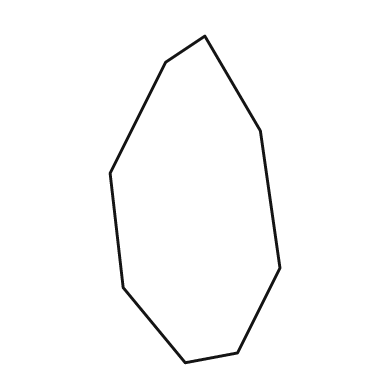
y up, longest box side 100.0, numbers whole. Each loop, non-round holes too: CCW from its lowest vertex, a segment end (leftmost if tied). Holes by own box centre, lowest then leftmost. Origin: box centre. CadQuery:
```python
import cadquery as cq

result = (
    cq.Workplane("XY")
    .moveTo(-3.0, -50.0)
    .lineTo(13.0, -47.0)
    .lineTo(26.0, -21.0)
    .lineTo(20.0, 21.0)
    .lineTo(3.0, 50.0)
    .lineTo(-9.0, 42.0)
    .lineTo(-26.0, 8.0)
    .lineTo(-22.0, -27.0)
    .close()
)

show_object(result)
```